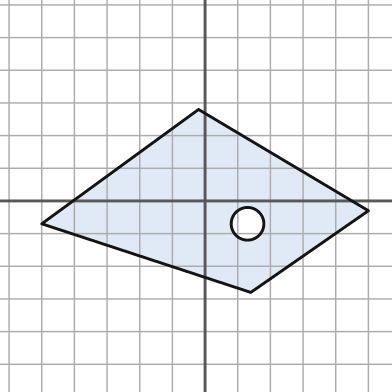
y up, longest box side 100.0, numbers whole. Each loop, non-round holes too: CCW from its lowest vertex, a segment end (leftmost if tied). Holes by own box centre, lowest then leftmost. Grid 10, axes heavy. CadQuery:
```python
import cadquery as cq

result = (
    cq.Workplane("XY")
    .moveTo(14.0, -28.0)
    .lineTo(50.0, -3.0)
    .lineTo(-2.0, 28.0)
    .lineTo(-50.0, -7.0)
    .close()
    .moveTo(13.0, -7.0)
    .circle(5.0)
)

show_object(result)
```